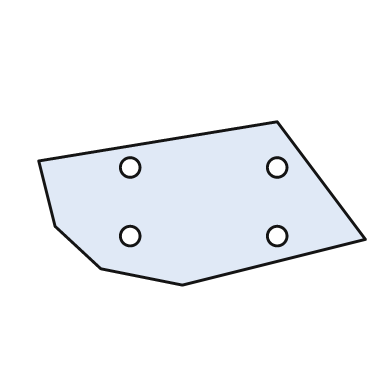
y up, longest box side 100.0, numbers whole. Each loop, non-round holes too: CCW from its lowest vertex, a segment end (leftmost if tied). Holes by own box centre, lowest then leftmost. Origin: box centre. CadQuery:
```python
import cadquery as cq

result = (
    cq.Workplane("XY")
    .moveTo(-6.0, -25.0)
    .lineTo(50.0, -11.0)
    .lineTo(23.0, 25.0)
    .lineTo(-50.0, 13.0)
    .lineTo(-45.0, -7.0)
    .lineTo(-31.0, -20.0)
    .close()
    .moveTo(-22.0, -10.0)
    .circle(3.0)
    .moveTo(23.0, -10.0)
    .circle(3.0)
    .moveTo(-22.0, 11.0)
    .circle(3.0)
    .moveTo(23.0, 11.0)
    .circle(3.0)
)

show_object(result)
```